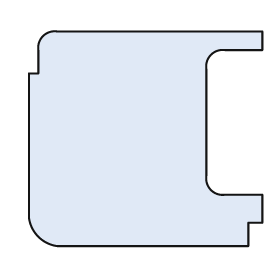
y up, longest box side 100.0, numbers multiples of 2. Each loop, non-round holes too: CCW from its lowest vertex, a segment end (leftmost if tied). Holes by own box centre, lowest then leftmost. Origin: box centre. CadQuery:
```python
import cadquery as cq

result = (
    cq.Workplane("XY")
    .moveTo(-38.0, -46.0)
    .lineTo(44.0, -46.0)
    .lineTo(44.0, -36.0)
    .lineTo(50.0, -36.0)
    .lineTo(50.0, -24.0)
    .lineTo(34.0, -24.0)
    .threePointArc((28.0, -22.0), (26.0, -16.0))
    .lineTo(26.0, 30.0)
    .threePointArc((28.0, 36.0), (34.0, 38.0))
    .lineTo(50.0, 38.0)
    .lineTo(50.0, 46.0)
    .lineTo(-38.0, 46.0)
    .threePointArc((-44.0, 44.0), (-46.0, 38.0))
    .lineTo(-46.0, 28.0)
    .lineTo(-50.0, 28.0)
    .lineTo(-50.0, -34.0)
    .threePointArc((-46.0, -42.0), (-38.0, -46.0))
    .close()
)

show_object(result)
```